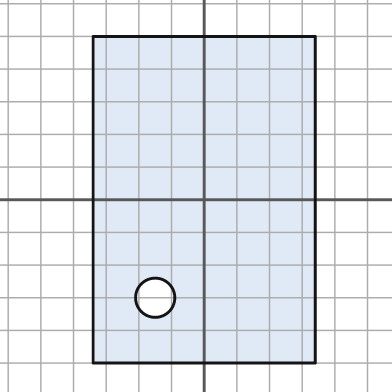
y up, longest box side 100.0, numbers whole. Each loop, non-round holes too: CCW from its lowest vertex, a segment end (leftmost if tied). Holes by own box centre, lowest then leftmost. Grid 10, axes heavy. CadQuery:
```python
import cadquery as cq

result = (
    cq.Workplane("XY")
    .moveTo(-34.0, -50.0)
    .lineTo(34.0, -50.0)
    .lineTo(34.0, 50.0)
    .lineTo(-34.0, 50.0)
    .close()
    .moveTo(-15.0, -30.0)
    .circle(6.0)
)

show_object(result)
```